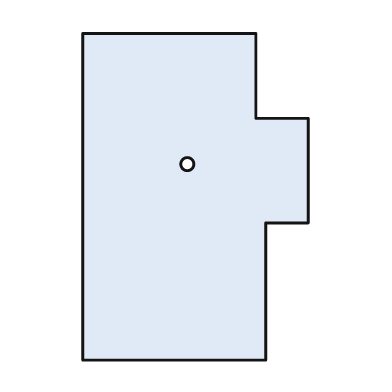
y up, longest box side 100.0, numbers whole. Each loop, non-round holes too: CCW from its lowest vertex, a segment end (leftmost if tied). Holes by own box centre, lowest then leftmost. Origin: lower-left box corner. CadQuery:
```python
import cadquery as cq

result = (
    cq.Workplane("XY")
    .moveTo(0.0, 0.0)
    .lineTo(56.0, 0.0)
    .lineTo(56.0, 42.0)
    .lineTo(69.0, 42.0)
    .lineTo(69.0, 74.0)
    .lineTo(53.0, 74.0)
    .lineTo(53.0, 100.0)
    .lineTo(0.0, 100.0)
    .close()
    .moveTo(32.0, 60.0)
    .circle(2.0)
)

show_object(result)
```